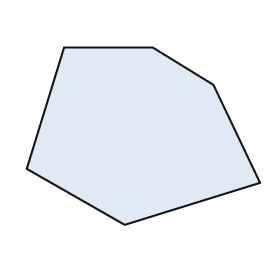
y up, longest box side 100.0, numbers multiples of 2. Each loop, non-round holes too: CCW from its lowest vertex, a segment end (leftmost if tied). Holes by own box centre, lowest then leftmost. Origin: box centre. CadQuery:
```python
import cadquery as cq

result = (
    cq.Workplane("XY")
    .moveTo(-8.0, -38.0)
    .lineTo(50.0, -20.0)
    .lineTo(30.0, 22.0)
    .lineTo(4.0, 38.0)
    .lineTo(-34.0, 38.0)
    .lineTo(-50.0, -14.0)
    .close()
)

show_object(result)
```